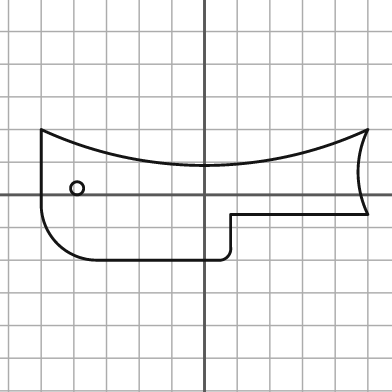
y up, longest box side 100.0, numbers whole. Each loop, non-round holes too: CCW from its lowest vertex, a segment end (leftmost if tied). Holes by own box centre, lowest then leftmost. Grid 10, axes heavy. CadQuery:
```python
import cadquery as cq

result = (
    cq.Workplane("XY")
    .moveTo(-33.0, -20.0)
    .lineTo(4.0, -20.0)
    .threePointArc((7.0, -19.0), (8.0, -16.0))
    .lineTo(8.0, -6.0)
    .lineTo(50.0, -6.0)
    .threePointArc((47.0, 7.0), (50.0, 20.0))
    .threePointArc((0.0, 9.0), (-50.0, 20.0))
    .lineTo(-50.0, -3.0)
    .threePointArc((-45.0, -15.0), (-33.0, -20.0))
    .close()
    .moveTo(-39.0, 2.0)
    .circle(2.0)
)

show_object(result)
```